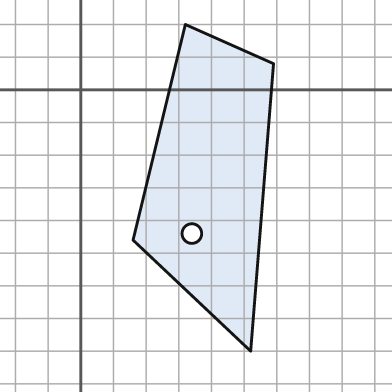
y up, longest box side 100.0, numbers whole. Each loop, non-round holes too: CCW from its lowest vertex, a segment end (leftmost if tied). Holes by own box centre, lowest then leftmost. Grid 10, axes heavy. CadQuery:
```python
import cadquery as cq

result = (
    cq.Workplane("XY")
    .moveTo(52.0, -80.0)
    .lineTo(59.0, 8.0)
    .lineTo(32.0, 20.0)
    .lineTo(16.0, -46.0)
    .close()
    .moveTo(34.0, -44.0)
    .circle(3.0)
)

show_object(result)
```